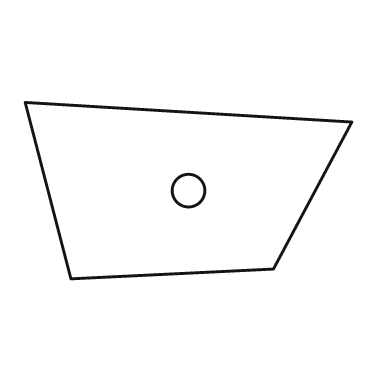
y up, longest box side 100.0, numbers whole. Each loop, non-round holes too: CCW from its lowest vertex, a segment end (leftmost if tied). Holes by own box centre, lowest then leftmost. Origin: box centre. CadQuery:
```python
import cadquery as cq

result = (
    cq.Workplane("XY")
    .moveTo(-36.0, -27.0)
    .lineTo(26.0, -24.0)
    .lineTo(50.0, 21.0)
    .lineTo(-50.0, 27.0)
    .close()
    .moveTo(0.0, 0.0)
    .circle(5.0)
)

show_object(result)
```